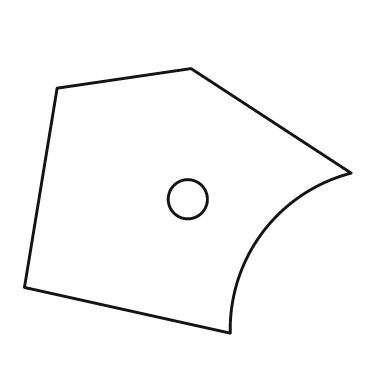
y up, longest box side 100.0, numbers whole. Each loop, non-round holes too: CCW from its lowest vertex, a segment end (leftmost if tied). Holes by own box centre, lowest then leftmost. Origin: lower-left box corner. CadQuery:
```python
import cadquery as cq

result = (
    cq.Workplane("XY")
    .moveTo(63.0, 0.0)
    .threePointArc((73.0, 31.0), (100.0, 49.0))
    .lineTo(51.0, 81.0)
    .lineTo(10.0, 75.0)
    .lineTo(0.0, 14.0)
    .close()
    .moveTo(50.0, 41.0)
    .circle(6.0)
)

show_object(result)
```